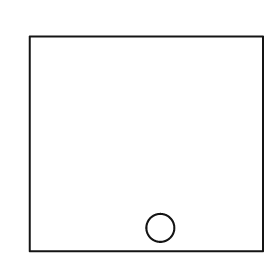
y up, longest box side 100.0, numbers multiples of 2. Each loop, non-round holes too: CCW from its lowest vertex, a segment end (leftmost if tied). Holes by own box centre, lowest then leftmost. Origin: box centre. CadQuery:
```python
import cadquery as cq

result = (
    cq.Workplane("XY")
    .moveTo(-50.0, -46.0)
    .lineTo(50.0, -46.0)
    .lineTo(50.0, 46.0)
    .lineTo(-50.0, 46.0)
    .close()
    .moveTo(6.0, -36.0)
    .circle(6.0)
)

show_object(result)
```